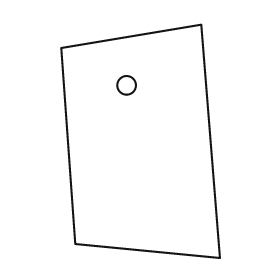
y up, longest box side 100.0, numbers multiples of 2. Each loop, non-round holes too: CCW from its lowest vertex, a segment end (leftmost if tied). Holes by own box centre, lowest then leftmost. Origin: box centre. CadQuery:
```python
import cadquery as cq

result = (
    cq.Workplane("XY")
    .moveTo(34.0, -50.0)
    .lineTo(26.0, 50.0)
    .lineTo(-34.0, 40.0)
    .lineTo(-28.0, -44.0)
    .close()
    .moveTo(-6.0, 24.0)
    .circle(4.0)
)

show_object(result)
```